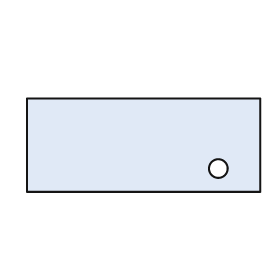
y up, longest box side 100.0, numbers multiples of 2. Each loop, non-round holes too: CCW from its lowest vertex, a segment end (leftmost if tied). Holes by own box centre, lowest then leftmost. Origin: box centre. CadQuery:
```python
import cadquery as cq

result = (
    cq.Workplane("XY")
    .moveTo(-50.0, -20.0)
    .lineTo(50.0, -20.0)
    .lineTo(50.0, 20.0)
    .lineTo(-50.0, 20.0)
    .close()
    .moveTo(32.0, -10.0)
    .circle(4.0)
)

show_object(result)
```